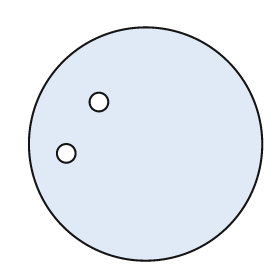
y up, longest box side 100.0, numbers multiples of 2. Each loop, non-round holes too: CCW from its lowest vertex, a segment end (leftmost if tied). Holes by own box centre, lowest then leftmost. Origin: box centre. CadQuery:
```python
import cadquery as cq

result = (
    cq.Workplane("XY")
    .moveTo(0.0, 0.0)
    .circle(50.0)
    .moveTo(-34.0, -4.0)
    .circle(4.0)
    .moveTo(-20.0, 18.0)
    .circle(4.0)
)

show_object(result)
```